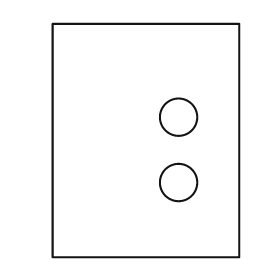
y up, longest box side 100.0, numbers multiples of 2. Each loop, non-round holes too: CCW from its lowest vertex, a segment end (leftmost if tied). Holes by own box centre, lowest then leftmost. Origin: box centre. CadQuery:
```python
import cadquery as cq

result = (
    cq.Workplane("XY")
    .moveTo(-40.0, -50.0)
    .lineTo(40.0, -50.0)
    .lineTo(40.0, 50.0)
    .lineTo(-40.0, 50.0)
    .close()
    .moveTo(14.0, -18.0)
    .circle(8.0)
    .moveTo(14.0, 10.0)
    .circle(8.0)
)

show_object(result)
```